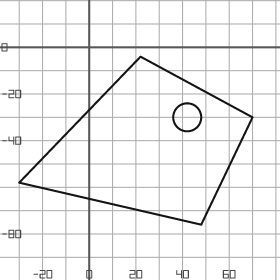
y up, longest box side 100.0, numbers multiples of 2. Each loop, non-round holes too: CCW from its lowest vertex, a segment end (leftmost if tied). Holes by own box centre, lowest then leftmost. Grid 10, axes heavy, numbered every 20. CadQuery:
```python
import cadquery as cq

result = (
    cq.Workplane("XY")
    .moveTo(48.0, -76.0)
    .lineTo(70.0, -30.0)
    .lineTo(22.0, -4.0)
    .lineTo(-30.0, -58.0)
    .close()
    .moveTo(42.0, -30.0)
    .circle(6.0)
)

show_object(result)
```